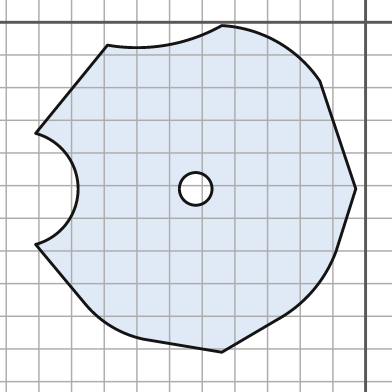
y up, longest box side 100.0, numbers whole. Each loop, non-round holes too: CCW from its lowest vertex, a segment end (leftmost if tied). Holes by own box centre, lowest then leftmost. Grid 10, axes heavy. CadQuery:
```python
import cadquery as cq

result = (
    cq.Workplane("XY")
    .moveTo(-44.0, -101.0)
    .lineTo(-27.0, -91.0)
    .threePointArc((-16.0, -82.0), (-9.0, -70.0))
    .lineTo(-3.0, -51.0)
    .lineTo(-14.0, -18.0)
    .threePointArc((-27.0, -6.0), (-44.0, -1.0))
    .threePointArc((-61.0, -7.0), (-79.0, -7.0))
    .lineTo(-101.0, -34.0)
    .threePointArc((-88.0, -51.0), (-101.0, -68.0))
    .lineTo(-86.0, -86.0)
    .threePointArc((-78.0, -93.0), (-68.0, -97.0))
    .close()
    .moveTo(-52.0, -51.0)
    .circle(5.0)
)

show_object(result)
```